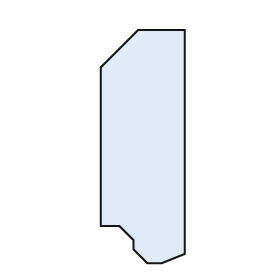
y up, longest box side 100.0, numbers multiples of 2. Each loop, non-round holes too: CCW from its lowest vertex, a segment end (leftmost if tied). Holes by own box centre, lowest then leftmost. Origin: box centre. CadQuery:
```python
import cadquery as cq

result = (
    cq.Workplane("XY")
    .moveTo(2.0, -50.0)
    .lineTo(8.0, -50.0)
    .lineTo(18.0, -46.0)
    .lineTo(18.0, 50.0)
    .lineTo(-2.0, 50.0)
    .lineTo(-18.0, 34.0)
    .lineTo(-18.0, -34.0)
    .lineTo(-10.0, -34.0)
    .lineTo(-4.0, -40.0)
    .lineTo(-4.0, -44.0)
    .close()
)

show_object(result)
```